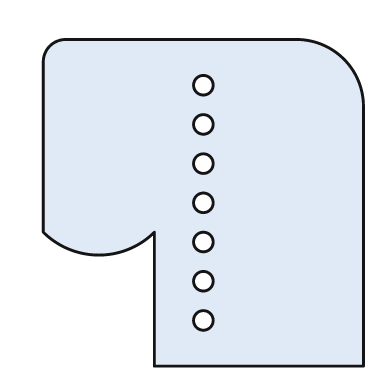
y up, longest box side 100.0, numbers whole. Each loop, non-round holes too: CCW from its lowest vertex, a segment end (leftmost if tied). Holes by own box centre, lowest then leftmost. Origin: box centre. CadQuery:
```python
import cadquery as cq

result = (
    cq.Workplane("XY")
    .moveTo(-15.0, -50.0)
    .lineTo(49.0, -50.0)
    .lineTo(49.0, 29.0)
    .threePointArc((43.0, 44.0), (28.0, 50.0))
    .lineTo(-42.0, 50.0)
    .threePointArc((-47.0, 48.0), (-49.0, 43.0))
    .lineTo(-49.0, -9.0)
    .threePointArc((-32.0, -16.0), (-15.0, -9.0))
    .close()
    .moveTo(0.0, -36.0)
    .circle(3.0)
    .moveTo(0.0, -24.0)
    .circle(3.0)
    .moveTo(0.0, -12.0)
    .circle(3.0)
    .moveTo(0.0, 0.0)
    .circle(3.0)
    .moveTo(0.0, 12.0)
    .circle(3.0)
    .moveTo(0.0, 24.0)
    .circle(3.0)
    .moveTo(0.0, 36.0)
    .circle(3.0)
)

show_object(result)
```